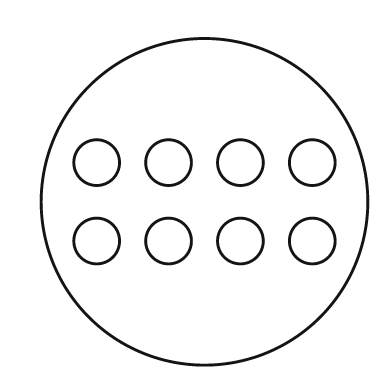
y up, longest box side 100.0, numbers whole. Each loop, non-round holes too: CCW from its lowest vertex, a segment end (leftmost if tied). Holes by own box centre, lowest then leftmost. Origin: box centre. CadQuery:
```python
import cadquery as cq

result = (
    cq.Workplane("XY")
    .moveTo(0.0, 0.0)
    .circle(50.0)
    .moveTo(-33.0, -12.0)
    .circle(7.0)
    .moveTo(-11.0, -12.0)
    .circle(7.0)
    .moveTo(11.0, -12.0)
    .circle(7.0)
    .moveTo(33.0, -12.0)
    .circle(7.0)
    .moveTo(-33.0, 12.0)
    .circle(7.0)
    .moveTo(-11.0, 12.0)
    .circle(7.0)
    .moveTo(11.0, 12.0)
    .circle(7.0)
    .moveTo(33.0, 12.0)
    .circle(7.0)
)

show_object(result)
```